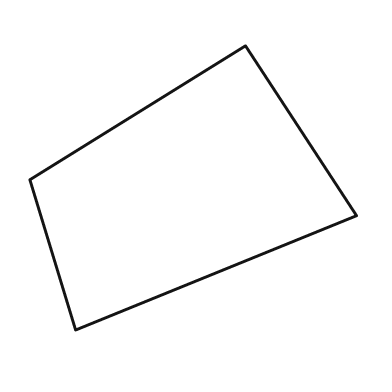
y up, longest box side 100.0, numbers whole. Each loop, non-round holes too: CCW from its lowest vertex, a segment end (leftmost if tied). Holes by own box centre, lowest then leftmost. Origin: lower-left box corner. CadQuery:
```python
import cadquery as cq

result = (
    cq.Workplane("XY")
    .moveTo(14.0, 0.0)
    .lineTo(100.0, 35.0)
    .lineTo(66.0, 87.0)
    .lineTo(0.0, 46.0)
    .close()
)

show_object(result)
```